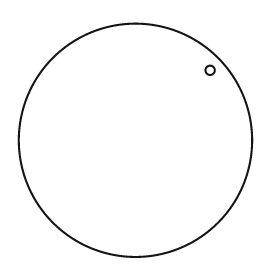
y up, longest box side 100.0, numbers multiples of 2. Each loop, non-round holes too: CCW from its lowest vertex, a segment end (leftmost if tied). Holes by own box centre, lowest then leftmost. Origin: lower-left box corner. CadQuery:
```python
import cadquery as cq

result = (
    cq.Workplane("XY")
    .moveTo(50.0, 50.0)
    .circle(50.0)
    .moveTo(82.0, 80.0)
    .circle(2.0)
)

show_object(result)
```